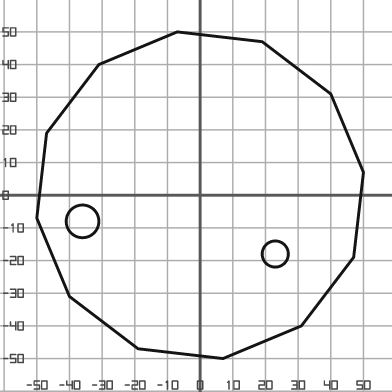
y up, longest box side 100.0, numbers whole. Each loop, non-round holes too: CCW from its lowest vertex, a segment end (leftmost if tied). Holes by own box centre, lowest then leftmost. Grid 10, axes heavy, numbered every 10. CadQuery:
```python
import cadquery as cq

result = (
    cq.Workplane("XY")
    .moveTo(7.0, -50.0)
    .lineTo(31.0, -40.0)
    .lineTo(47.0, -19.0)
    .lineTo(50.0, 7.0)
    .lineTo(40.0, 31.0)
    .lineTo(19.0, 47.0)
    .lineTo(-7.0, 50.0)
    .lineTo(-31.0, 40.0)
    .lineTo(-47.0, 19.0)
    .lineTo(-50.0, -7.0)
    .lineTo(-40.0, -31.0)
    .lineTo(-19.0, -47.0)
    .close()
    .moveTo(23.0, -18.0)
    .circle(4.0)
    .moveTo(-36.0, -8.0)
    .circle(5.0)
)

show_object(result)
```